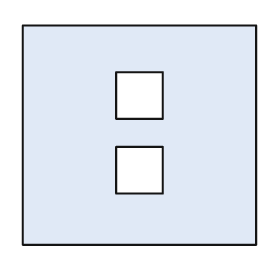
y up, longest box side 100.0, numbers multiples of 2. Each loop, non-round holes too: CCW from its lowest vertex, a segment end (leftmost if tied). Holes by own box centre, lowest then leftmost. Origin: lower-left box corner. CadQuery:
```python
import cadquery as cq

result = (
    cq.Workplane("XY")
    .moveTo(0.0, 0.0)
    .lineTo(100.0, 0.0)
    .lineTo(100.0, 94.0)
    .lineTo(0.0, 94.0)
    .close()
    .moveTo(40.0, 22.0)
    .lineTo(60.0, 22.0)
    .lineTo(60.0, 42.0)
    .lineTo(40.0, 42.0)
    .close()
    .moveTo(40.0, 54.0)
    .lineTo(60.0, 54.0)
    .lineTo(60.0, 74.0)
    .lineTo(40.0, 74.0)
    .close()
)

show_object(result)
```